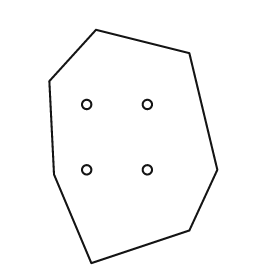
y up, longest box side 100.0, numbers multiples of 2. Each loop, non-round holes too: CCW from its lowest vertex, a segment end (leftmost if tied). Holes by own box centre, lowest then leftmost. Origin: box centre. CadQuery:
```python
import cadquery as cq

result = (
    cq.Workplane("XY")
    .moveTo(-18.0, -50.0)
    .lineTo(24.0, -36.0)
    .lineTo(36.0, -10.0)
    .lineTo(24.0, 40.0)
    .lineTo(-16.0, 50.0)
    .lineTo(-36.0, 28.0)
    .lineTo(-34.0, -12.0)
    .close()
    .moveTo(-20.0, -10.0)
    .circle(2.0)
    .moveTo(6.0, -10.0)
    .circle(2.0)
    .moveTo(-20.0, 18.0)
    .circle(2.0)
    .moveTo(6.0, 18.0)
    .circle(2.0)
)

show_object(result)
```